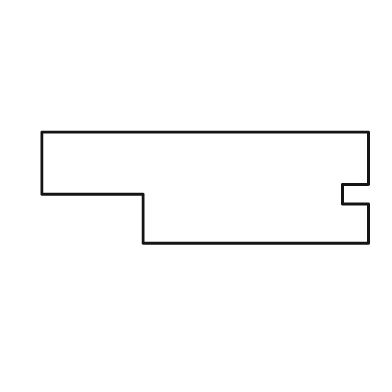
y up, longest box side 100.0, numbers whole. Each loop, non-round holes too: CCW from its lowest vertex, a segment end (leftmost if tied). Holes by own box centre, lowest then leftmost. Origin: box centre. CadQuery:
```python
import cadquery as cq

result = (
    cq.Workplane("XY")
    .moveTo(-19.0, -17.0)
    .lineTo(50.0, -17.0)
    .lineTo(50.0, -5.0)
    .lineTo(42.0, -5.0)
    .lineTo(42.0, 1.0)
    .lineTo(50.0, 1.0)
    .lineTo(50.0, 17.0)
    .lineTo(-50.0, 17.0)
    .lineTo(-50.0, -2.0)
    .lineTo(-19.0, -2.0)
    .close()
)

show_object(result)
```